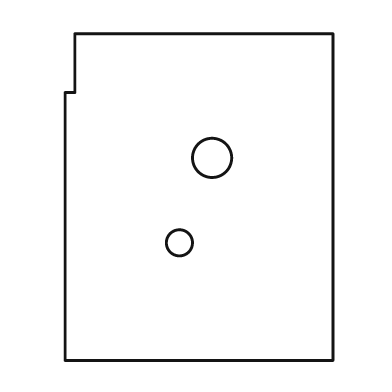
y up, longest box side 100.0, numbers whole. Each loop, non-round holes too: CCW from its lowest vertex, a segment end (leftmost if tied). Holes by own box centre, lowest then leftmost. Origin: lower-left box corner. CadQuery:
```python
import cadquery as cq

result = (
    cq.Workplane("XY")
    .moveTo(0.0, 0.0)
    .lineTo(82.0, 0.0)
    .lineTo(82.0, 100.0)
    .lineTo(3.0, 100.0)
    .lineTo(3.0, 82.0)
    .lineTo(0.0, 82.0)
    .close()
    .moveTo(35.0, 36.0)
    .circle(4.0)
    .moveTo(45.0, 62.0)
    .circle(6.0)
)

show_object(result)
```